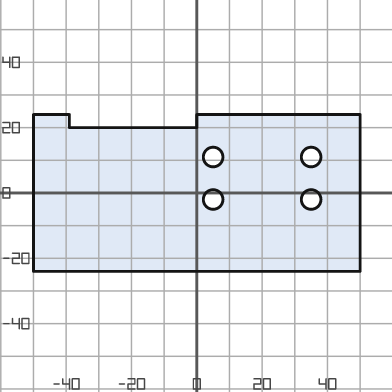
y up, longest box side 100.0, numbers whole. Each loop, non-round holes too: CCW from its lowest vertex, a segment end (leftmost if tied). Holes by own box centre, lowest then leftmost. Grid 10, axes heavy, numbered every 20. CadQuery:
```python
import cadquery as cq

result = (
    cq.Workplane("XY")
    .moveTo(-50.0, -24.0)
    .lineTo(50.0, -24.0)
    .lineTo(50.0, 24.0)
    .lineTo(0.0, 24.0)
    .lineTo(0.0, 20.0)
    .lineTo(-39.0, 20.0)
    .lineTo(-39.0, 24.0)
    .lineTo(-50.0, 24.0)
    .close()
    .moveTo(5.0, -2.0)
    .circle(3.0)
    .moveTo(35.0, -2.0)
    .circle(3.0)
    .moveTo(5.0, 11.0)
    .circle(3.0)
    .moveTo(35.0, 11.0)
    .circle(3.0)
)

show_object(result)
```